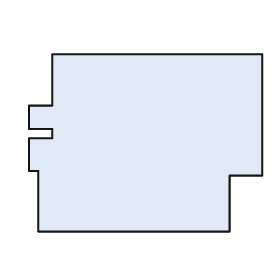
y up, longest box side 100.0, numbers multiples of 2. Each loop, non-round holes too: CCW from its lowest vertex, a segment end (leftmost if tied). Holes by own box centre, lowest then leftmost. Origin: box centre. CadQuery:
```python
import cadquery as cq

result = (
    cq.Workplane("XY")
    .moveTo(-46.0, -38.0)
    .lineTo(36.0, -38.0)
    .lineTo(36.0, -14.0)
    .lineTo(50.0, -14.0)
    .lineTo(50.0, 38.0)
    .lineTo(-40.0, 38.0)
    .lineTo(-40.0, 16.0)
    .lineTo(-50.0, 16.0)
    .lineTo(-50.0, 6.0)
    .lineTo(-40.0, 6.0)
    .lineTo(-40.0, 2.0)
    .lineTo(-50.0, 2.0)
    .lineTo(-50.0, -12.0)
    .lineTo(-46.0, -12.0)
    .close()
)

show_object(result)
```